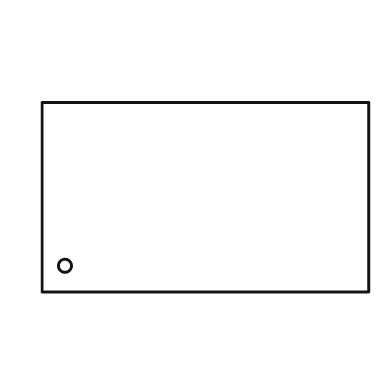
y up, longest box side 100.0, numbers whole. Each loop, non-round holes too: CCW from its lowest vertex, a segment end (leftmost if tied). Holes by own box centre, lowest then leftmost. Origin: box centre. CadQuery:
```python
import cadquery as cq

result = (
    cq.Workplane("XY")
    .moveTo(-50.0, -29.0)
    .lineTo(50.0, -29.0)
    .lineTo(50.0, 29.0)
    .lineTo(-50.0, 29.0)
    .close()
    .moveTo(-43.0, -21.0)
    .circle(2.0)
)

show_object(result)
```